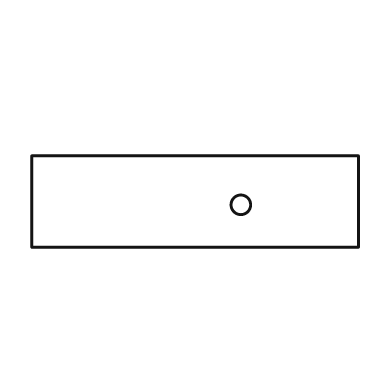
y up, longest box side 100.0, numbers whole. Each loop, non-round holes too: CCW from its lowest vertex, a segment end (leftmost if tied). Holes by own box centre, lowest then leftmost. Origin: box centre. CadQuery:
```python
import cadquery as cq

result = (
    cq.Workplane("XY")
    .moveTo(-50.0, -14.0)
    .lineTo(50.0, -14.0)
    .lineTo(50.0, 14.0)
    .lineTo(-50.0, 14.0)
    .close()
    .moveTo(14.0, -1.0)
    .circle(3.0)
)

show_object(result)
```